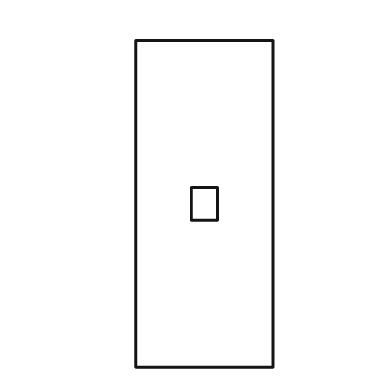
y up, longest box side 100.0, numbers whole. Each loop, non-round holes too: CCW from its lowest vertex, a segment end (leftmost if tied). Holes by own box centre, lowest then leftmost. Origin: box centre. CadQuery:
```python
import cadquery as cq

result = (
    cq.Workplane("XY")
    .moveTo(-21.0, -50.0)
    .lineTo(21.0, -50.0)
    .lineTo(21.0, 50.0)
    .lineTo(-21.0, 50.0)
    .close()
    .moveTo(-4.0, -5.0)
    .lineTo(4.0, -5.0)
    .lineTo(4.0, 5.0)
    .lineTo(-4.0, 5.0)
    .close()
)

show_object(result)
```